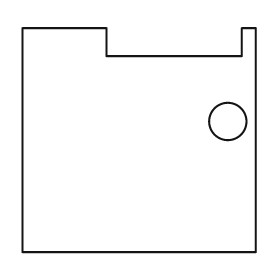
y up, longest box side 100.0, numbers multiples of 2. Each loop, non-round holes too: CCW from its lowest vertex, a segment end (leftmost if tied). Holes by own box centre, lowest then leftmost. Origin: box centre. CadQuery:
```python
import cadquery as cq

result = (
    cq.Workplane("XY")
    .moveTo(-50.0, -48.0)
    .lineTo(50.0, -48.0)
    .lineTo(50.0, 48.0)
    .lineTo(44.0, 48.0)
    .lineTo(44.0, 36.0)
    .lineTo(-14.0, 36.0)
    .lineTo(-14.0, 48.0)
    .lineTo(-50.0, 48.0)
    .close()
    .moveTo(38.0, 8.0)
    .circle(8.0)
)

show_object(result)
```